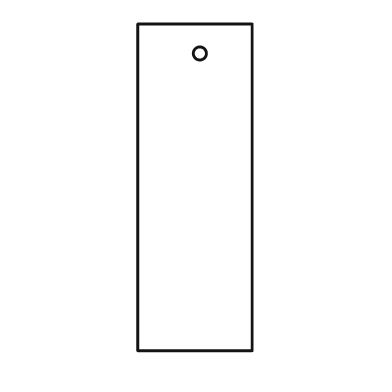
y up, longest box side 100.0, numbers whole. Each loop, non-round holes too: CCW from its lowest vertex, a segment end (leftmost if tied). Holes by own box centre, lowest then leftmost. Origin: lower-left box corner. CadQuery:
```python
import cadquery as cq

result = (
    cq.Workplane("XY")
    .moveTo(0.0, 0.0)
    .lineTo(35.0, 0.0)
    .lineTo(35.0, 100.0)
    .lineTo(0.0, 100.0)
    .close()
    .moveTo(19.0, 91.0)
    .circle(2.0)
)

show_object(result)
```